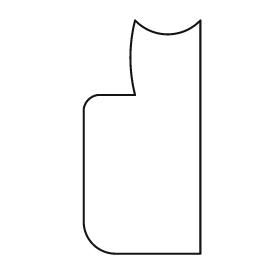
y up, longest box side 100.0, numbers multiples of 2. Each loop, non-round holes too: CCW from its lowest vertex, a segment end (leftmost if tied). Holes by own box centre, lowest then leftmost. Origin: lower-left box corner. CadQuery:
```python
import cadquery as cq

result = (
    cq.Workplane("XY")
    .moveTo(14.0, 0.0)
    .lineTo(50.0, 0.0)
    .lineTo(50.0, 100.0)
    .threePointArc((36.0, 94.0), (22.0, 100.0))
    .threePointArc((20.0, 84.0), (22.0, 68.0))
    .lineTo(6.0, 68.0)
    .threePointArc((2.0, 66.0), (0.0, 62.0))
    .lineTo(0.0, 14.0)
    .threePointArc((4.0, 4.0), (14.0, 0.0))
    .close()
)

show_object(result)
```